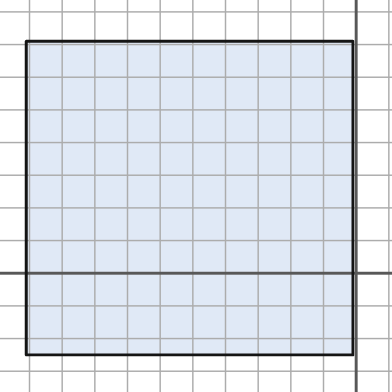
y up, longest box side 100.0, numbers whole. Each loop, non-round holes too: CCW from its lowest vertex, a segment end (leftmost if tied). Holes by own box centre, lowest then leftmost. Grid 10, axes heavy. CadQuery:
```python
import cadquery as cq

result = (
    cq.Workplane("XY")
    .moveTo(-101.0, -25.0)
    .lineTo(-1.0, -25.0)
    .lineTo(-1.0, 71.0)
    .lineTo(-101.0, 71.0)
    .close()
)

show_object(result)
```